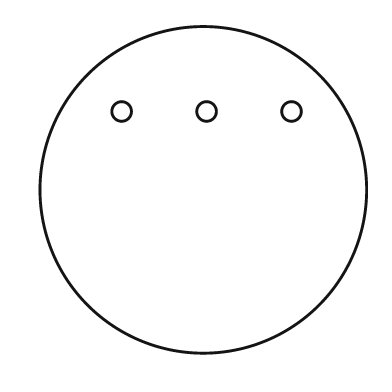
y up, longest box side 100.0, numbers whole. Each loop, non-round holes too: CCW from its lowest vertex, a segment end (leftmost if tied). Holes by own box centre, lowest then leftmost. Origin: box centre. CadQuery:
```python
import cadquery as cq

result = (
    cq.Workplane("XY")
    .moveTo(0.0, 0.0)
    .circle(50.0)
    .moveTo(-25.0, 24.0)
    .circle(3.0)
    .moveTo(1.0, 24.0)
    .circle(3.0)
    .moveTo(27.0, 24.0)
    .circle(3.0)
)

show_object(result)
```